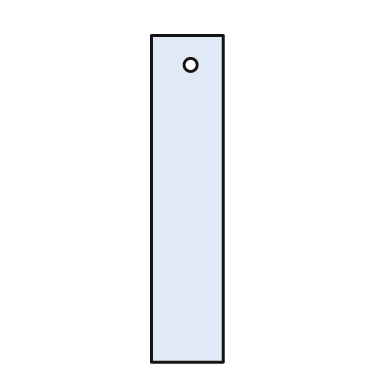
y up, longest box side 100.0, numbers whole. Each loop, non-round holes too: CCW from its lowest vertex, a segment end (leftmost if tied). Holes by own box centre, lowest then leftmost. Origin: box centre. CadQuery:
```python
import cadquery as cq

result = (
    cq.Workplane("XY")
    .moveTo(-11.0, -50.0)
    .lineTo(11.0, -50.0)
    .lineTo(11.0, 50.0)
    .lineTo(-11.0, 50.0)
    .close()
    .moveTo(1.0, 41.0)
    .circle(2.0)
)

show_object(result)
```